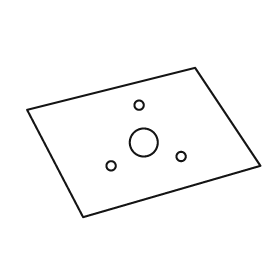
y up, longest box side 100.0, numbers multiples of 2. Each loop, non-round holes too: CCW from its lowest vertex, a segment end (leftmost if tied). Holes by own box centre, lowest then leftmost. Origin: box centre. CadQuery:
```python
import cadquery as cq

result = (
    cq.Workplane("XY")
    .moveTo(-26.0, -32.0)
    .lineTo(50.0, -10.0)
    .lineTo(22.0, 32.0)
    .lineTo(-50.0, 14.0)
    .close()
    .moveTo(-14.0, -10.0)
    .circle(2.0)
    .moveTo(16.0, -6.0)
    .circle(2.0)
    .moveTo(0.0, 0.0)
    .circle(6.0)
    .moveTo(-2.0, 16.0)
    .circle(2.0)
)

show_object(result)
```